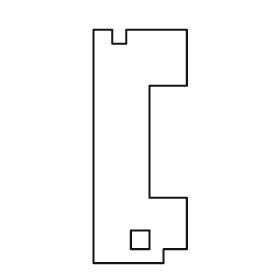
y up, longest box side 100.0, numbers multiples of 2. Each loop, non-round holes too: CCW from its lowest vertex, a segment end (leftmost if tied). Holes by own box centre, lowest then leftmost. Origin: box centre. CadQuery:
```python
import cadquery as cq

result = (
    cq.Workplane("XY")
    .moveTo(-20.0, -50.0)
    .lineTo(10.0, -50.0)
    .lineTo(10.0, -44.0)
    .lineTo(20.0, -44.0)
    .lineTo(20.0, -22.0)
    .lineTo(4.0, -22.0)
    .lineTo(4.0, 26.0)
    .lineTo(20.0, 26.0)
    .lineTo(20.0, 50.0)
    .lineTo(-6.0, 50.0)
    .lineTo(-6.0, 44.0)
    .lineTo(-12.0, 44.0)
    .lineTo(-12.0, 50.0)
    .lineTo(-20.0, 50.0)
    .close()
    .moveTo(-4.0, -44.0)
    .lineTo(4.0, -44.0)
    .lineTo(4.0, -36.0)
    .lineTo(-4.0, -36.0)
    .close()
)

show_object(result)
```